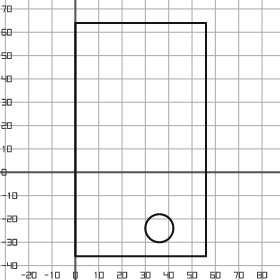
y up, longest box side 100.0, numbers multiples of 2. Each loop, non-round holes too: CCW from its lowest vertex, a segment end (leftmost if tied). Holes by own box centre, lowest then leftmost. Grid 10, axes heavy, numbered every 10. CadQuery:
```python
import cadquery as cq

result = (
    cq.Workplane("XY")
    .moveTo(0.0, -36.0)
    .lineTo(56.0, -36.0)
    .lineTo(56.0, 64.0)
    .lineTo(0.0, 64.0)
    .close()
    .moveTo(36.0, -24.0)
    .circle(6.0)
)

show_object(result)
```